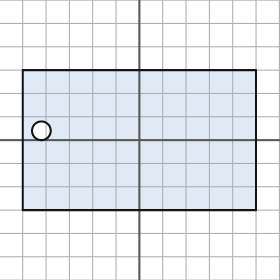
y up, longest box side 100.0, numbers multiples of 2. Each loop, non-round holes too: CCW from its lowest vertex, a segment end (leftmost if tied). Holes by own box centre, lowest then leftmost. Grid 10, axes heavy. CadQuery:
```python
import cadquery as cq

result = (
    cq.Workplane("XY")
    .moveTo(-50.0, -30.0)
    .lineTo(50.0, -30.0)
    .lineTo(50.0, 30.0)
    .lineTo(-50.0, 30.0)
    .close()
    .moveTo(-42.0, 4.0)
    .circle(4.0)
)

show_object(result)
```